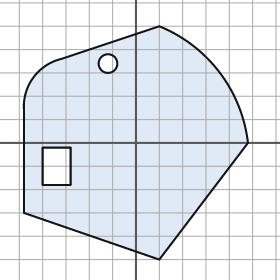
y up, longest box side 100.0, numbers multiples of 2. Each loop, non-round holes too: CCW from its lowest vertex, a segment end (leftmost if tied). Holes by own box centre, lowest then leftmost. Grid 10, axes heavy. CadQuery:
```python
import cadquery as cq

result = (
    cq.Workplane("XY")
    .moveTo(10.0, -50.0)
    .lineTo(48.0, 0.0)
    .threePointArc((36.0, 30.0), (10.0, 50.0))
    .lineTo(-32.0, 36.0)
    .threePointArc((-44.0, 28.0), (-48.0, 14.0))
    .lineTo(-48.0, -30.0)
    .close()
    .moveTo(-40.0, -18.0)
    .lineTo(-28.0, -18.0)
    .lineTo(-28.0, -2.0)
    .lineTo(-40.0, -2.0)
    .close()
    .moveTo(-12.0, 34.0)
    .circle(4.0)
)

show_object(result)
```